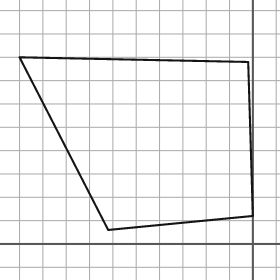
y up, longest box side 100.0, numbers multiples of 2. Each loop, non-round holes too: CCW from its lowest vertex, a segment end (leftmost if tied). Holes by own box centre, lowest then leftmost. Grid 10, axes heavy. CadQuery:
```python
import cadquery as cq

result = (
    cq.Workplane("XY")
    .moveTo(-62.0, 6.0)
    .lineTo(0.0, 12.0)
    .lineTo(-2.0, 78.0)
    .lineTo(-100.0, 80.0)
    .close()
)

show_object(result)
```